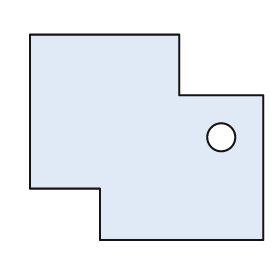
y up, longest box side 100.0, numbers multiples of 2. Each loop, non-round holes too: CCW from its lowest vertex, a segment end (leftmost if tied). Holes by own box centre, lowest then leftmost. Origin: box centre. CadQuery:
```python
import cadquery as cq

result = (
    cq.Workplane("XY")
    .moveTo(-20.0, -44.0)
    .lineTo(50.0, -44.0)
    .lineTo(50.0, 18.0)
    .lineTo(14.0, 18.0)
    .lineTo(14.0, 44.0)
    .lineTo(-50.0, 44.0)
    .lineTo(-50.0, -22.0)
    .lineTo(-20.0, -22.0)
    .close()
    .moveTo(32.0, 0.0)
    .circle(6.0)
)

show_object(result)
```